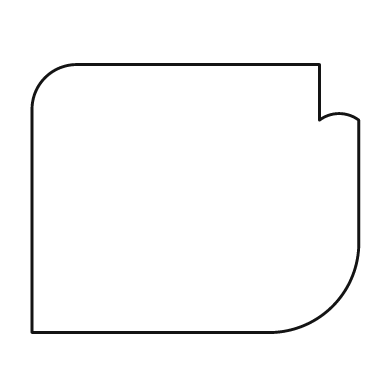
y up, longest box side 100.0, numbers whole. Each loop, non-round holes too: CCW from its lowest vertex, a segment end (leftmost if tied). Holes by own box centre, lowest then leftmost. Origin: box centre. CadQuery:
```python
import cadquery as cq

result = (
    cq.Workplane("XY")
    .moveTo(-50.0, -41.0)
    .lineTo(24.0, -41.0)
    .threePointArc((42.0, -33.0), (50.0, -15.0))
    .lineTo(50.0, 24.0)
    .threePointArc((44.0, 26.0), (38.0, 24.0))
    .lineTo(38.0, 41.0)
    .lineTo(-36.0, 41.0)
    .threePointArc((-46.0, 37.0), (-50.0, 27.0))
    .close()
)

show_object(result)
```